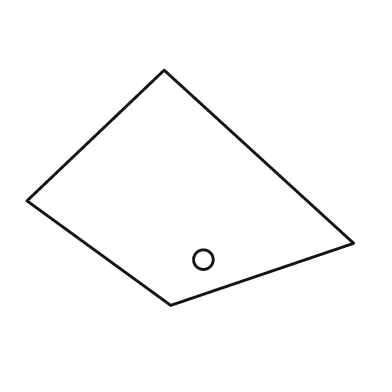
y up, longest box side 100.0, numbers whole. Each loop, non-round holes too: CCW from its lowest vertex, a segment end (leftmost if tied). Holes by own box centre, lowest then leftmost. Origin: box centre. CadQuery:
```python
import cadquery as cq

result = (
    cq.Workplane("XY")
    .moveTo(-6.0, -36.0)
    .lineTo(50.0, -17.0)
    .lineTo(-8.0, 36.0)
    .lineTo(-50.0, -4.0)
    .close()
    .moveTo(4.0, -22.0)
    .circle(3.0)
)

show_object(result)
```